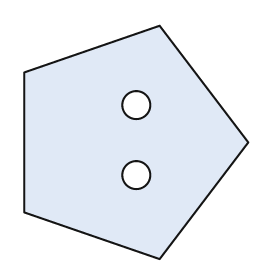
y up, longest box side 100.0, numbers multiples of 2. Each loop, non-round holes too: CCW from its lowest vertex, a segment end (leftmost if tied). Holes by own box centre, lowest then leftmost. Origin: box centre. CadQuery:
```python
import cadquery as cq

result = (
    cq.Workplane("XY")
    .moveTo(10.0, -50.0)
    .lineTo(48.0, 0.0)
    .lineTo(10.0, 50.0)
    .lineTo(-48.0, 30.0)
    .lineTo(-48.0, -30.0)
    .close()
    .moveTo(0.0, -14.0)
    .circle(6.0)
    .moveTo(0.0, 16.0)
    .circle(6.0)
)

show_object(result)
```